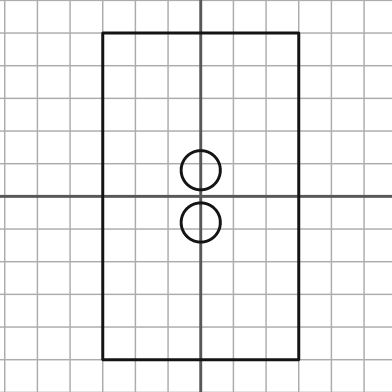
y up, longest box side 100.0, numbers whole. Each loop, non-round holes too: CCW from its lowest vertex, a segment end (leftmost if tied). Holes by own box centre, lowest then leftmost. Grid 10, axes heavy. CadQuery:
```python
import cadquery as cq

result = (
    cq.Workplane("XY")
    .moveTo(-30.0, -50.0)
    .lineTo(30.0, -50.0)
    .lineTo(30.0, 50.0)
    .lineTo(-30.0, 50.0)
    .close()
    .moveTo(0.0, -8.0)
    .circle(6.0)
    .moveTo(0.0, 8.0)
    .circle(6.0)
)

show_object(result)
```